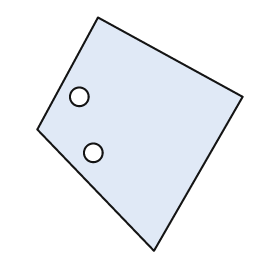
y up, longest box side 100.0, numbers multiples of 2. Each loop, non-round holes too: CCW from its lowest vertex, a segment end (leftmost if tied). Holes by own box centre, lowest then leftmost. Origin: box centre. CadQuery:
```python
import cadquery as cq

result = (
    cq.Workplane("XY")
    .moveTo(6.0, -50.0)
    .lineTo(44.0, 16.0)
    .lineTo(-18.0, 50.0)
    .lineTo(-44.0, 2.0)
    .close()
    .moveTo(-20.0, -8.0)
    .circle(4.0)
    .moveTo(-26.0, 16.0)
    .circle(4.0)
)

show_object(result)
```